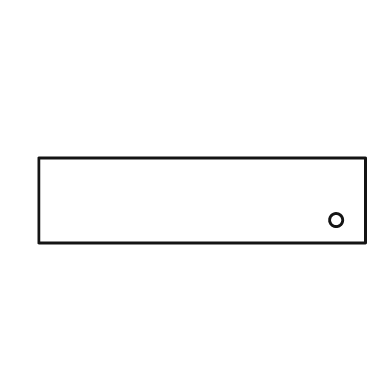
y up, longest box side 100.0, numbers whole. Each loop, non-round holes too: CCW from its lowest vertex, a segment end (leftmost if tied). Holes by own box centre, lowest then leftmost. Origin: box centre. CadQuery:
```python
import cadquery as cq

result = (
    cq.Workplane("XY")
    .moveTo(-50.0, -13.0)
    .lineTo(50.0, -13.0)
    .lineTo(50.0, 13.0)
    .lineTo(-50.0, 13.0)
    .close()
    .moveTo(41.0, -6.0)
    .circle(2.0)
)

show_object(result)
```